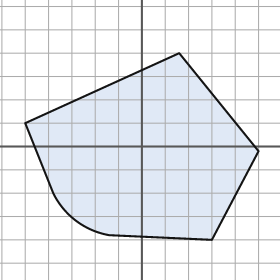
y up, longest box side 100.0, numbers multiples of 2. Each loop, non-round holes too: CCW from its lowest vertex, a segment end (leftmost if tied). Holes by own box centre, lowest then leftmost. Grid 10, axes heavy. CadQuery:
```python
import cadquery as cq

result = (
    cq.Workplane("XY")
    .moveTo(30.0, -40.0)
    .lineTo(50.0, -2.0)
    .lineTo(16.0, 40.0)
    .lineTo(-50.0, 10.0)
    .lineTo(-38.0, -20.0)
    .threePointArc((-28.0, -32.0), (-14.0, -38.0))
    .close()
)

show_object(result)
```